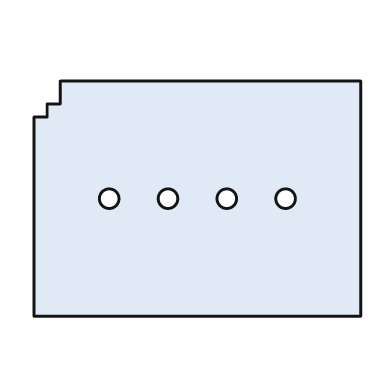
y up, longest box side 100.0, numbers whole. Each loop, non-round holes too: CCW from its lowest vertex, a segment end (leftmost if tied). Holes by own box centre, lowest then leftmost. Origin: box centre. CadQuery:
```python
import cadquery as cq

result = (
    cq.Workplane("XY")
    .moveTo(-50.0, -36.0)
    .lineTo(50.0, -36.0)
    .lineTo(50.0, 36.0)
    .lineTo(-42.0, 36.0)
    .lineTo(-42.0, 29.0)
    .lineTo(-46.0, 29.0)
    .lineTo(-46.0, 25.0)
    .lineTo(-50.0, 25.0)
    .close()
    .moveTo(-27.0, 0.0)
    .circle(3.0)
    .moveTo(-9.0, 0.0)
    .circle(3.0)
    .moveTo(9.0, 0.0)
    .circle(3.0)
    .moveTo(27.0, 0.0)
    .circle(3.0)
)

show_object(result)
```